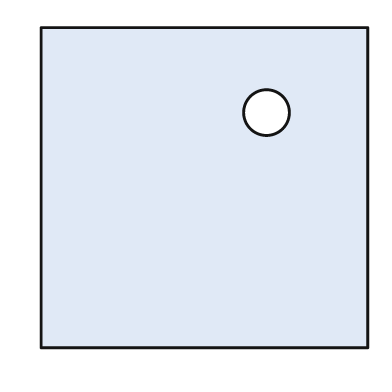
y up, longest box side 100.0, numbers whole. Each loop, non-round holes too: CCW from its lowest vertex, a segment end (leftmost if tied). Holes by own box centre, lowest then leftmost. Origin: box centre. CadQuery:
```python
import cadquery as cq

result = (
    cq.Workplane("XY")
    .moveTo(-50.0, -49.0)
    .lineTo(50.0, -49.0)
    .lineTo(50.0, 49.0)
    .lineTo(-50.0, 49.0)
    .close()
    .moveTo(19.0, 23.0)
    .circle(7.0)
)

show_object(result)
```